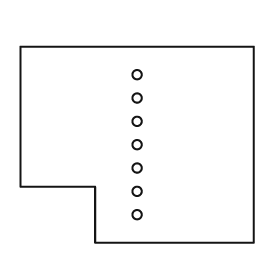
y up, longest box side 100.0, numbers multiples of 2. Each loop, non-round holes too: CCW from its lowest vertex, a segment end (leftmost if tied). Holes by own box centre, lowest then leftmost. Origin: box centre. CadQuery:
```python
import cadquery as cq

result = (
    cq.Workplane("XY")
    .moveTo(-18.0, -42.0)
    .lineTo(50.0, -42.0)
    .lineTo(50.0, 42.0)
    .lineTo(-50.0, 42.0)
    .lineTo(-50.0, -18.0)
    .lineTo(-18.0, -18.0)
    .close()
    .moveTo(0.0, -30.0)
    .circle(2.0)
    .moveTo(0.0, -20.0)
    .circle(2.0)
    .moveTo(0.0, -10.0)
    .circle(2.0)
    .moveTo(0.0, 0.0)
    .circle(2.0)
    .moveTo(0.0, 10.0)
    .circle(2.0)
    .moveTo(0.0, 20.0)
    .circle(2.0)
    .moveTo(0.0, 30.0)
    .circle(2.0)
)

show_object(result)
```